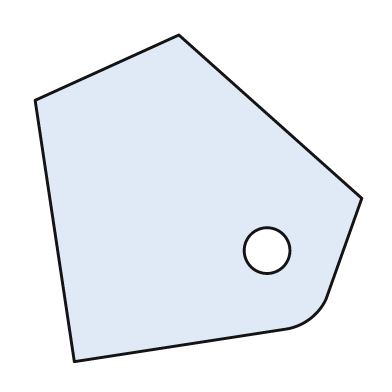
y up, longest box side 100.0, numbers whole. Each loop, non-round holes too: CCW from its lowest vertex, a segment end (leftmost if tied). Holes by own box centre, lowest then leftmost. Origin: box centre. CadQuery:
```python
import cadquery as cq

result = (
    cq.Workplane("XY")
    .moveTo(-38.0, -50.0)
    .lineTo(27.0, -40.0)
    .threePointArc((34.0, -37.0), (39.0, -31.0))
    .lineTo(50.0, 0.0)
    .lineTo(-6.0, 50.0)
    .lineTo(-50.0, 30.0)
    .close()
    .moveTo(21.0, -16.0)
    .circle(7.0)
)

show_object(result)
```